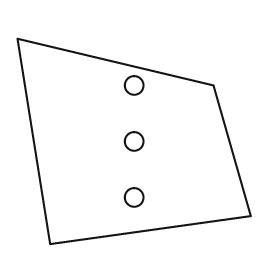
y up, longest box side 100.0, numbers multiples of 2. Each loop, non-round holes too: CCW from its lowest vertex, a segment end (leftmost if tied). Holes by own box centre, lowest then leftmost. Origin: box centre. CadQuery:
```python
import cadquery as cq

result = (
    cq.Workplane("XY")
    .moveTo(-36.0, -44.0)
    .lineTo(50.0, -32.0)
    .lineTo(34.0, 24.0)
    .lineTo(-50.0, 44.0)
    .close()
    .moveTo(0.0, -24.0)
    .circle(4.0)
    .moveTo(0.0, 0.0)
    .circle(4.0)
    .moveTo(0.0, 24.0)
    .circle(4.0)
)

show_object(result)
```